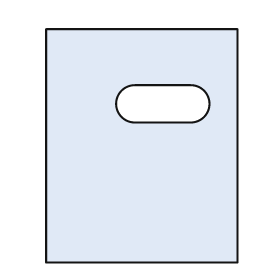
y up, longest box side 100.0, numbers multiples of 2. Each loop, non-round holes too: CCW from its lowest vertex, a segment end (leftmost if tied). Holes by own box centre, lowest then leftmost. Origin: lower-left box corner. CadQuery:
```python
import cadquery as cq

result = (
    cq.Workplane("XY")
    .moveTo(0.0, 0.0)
    .lineTo(82.0, 0.0)
    .lineTo(82.0, 100.0)
    .lineTo(0.0, 100.0)
    .close()
    .moveTo(38.0, 60.0)
    .lineTo(62.0, 60.0)
    .threePointArc((70.0, 68.0), (62.0, 76.0))
    .lineTo(38.0, 76.0)
    .threePointArc((30.0, 68.0), (38.0, 60.0))
    .close()
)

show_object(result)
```